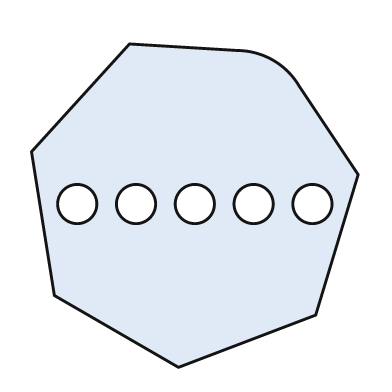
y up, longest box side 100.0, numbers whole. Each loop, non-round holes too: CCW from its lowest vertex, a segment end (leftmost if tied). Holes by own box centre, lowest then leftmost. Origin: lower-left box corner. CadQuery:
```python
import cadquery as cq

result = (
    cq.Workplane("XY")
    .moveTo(45.0, 0.0)
    .lineTo(87.0, 16.0)
    .lineTo(100.0, 59.0)
    .lineTo(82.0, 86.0)
    .threePointArc((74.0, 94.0), (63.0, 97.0))
    .lineTo(30.0, 99.0)
    .lineTo(0.0, 66.0)
    .lineTo(7.0, 22.0)
    .close()
    .moveTo(14.0, 50.0)
    .circle(6.0)
    .moveTo(32.0, 50.0)
    .circle(6.0)
    .moveTo(50.0, 50.0)
    .circle(6.0)
    .moveTo(68.0, 50.0)
    .circle(6.0)
    .moveTo(86.0, 50.0)
    .circle(6.0)
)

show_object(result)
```